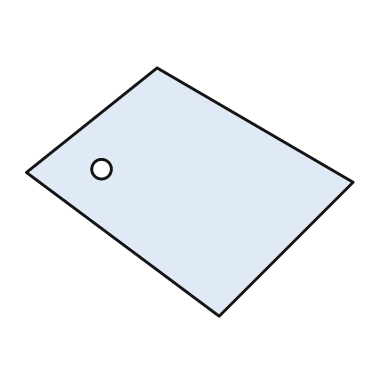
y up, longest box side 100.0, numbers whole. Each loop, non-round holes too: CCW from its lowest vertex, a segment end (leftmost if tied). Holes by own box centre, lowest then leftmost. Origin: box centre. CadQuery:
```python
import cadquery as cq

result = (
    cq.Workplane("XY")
    .moveTo(9.0, -38.0)
    .lineTo(50.0, 3.0)
    .lineTo(-10.0, 38.0)
    .lineTo(-50.0, 6.0)
    .close()
    .moveTo(-27.0, 7.0)
    .circle(3.0)
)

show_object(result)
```